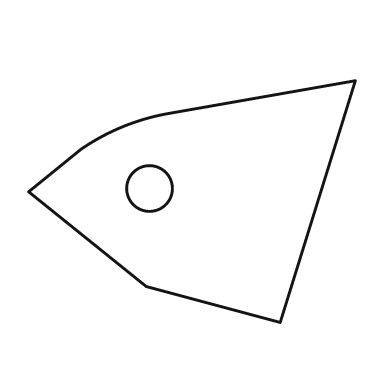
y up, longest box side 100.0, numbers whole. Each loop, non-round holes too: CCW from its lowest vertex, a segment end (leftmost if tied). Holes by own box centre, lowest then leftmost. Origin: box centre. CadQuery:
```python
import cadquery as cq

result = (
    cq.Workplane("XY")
    .moveTo(27.0, -37.0)
    .lineTo(50.0, 37.0)
    .lineTo(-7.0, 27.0)
    .threePointArc((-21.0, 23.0), (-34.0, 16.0))
    .lineTo(-50.0, 3.0)
    .lineTo(-14.0, -26.0)
    .close()
    .moveTo(-13.0, 4.0)
    .circle(7.0)
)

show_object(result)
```